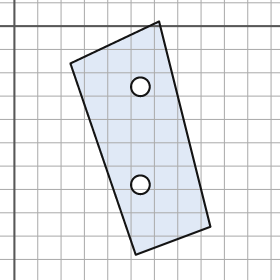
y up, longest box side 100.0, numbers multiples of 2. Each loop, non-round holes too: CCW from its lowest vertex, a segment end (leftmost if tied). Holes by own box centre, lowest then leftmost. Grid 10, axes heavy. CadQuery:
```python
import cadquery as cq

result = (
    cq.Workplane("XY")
    .moveTo(52.0, -98.0)
    .lineTo(84.0, -86.0)
    .lineTo(62.0, 2.0)
    .lineTo(24.0, -16.0)
    .close()
    .moveTo(54.0, -68.0)
    .circle(4.0)
    .moveTo(54.0, -26.0)
    .circle(4.0)
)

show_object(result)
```